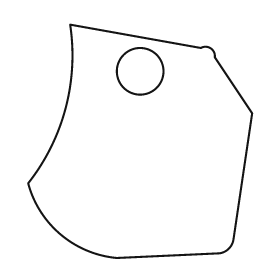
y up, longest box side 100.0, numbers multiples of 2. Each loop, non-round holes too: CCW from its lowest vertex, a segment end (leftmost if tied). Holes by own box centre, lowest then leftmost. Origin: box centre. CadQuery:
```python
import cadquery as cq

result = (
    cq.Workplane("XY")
    .moveTo(-10.0, -50.0)
    .lineTo(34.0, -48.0)
    .threePointArc((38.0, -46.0), (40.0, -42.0))
    .lineTo(48.0, 12.0)
    .lineTo(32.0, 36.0)
    .threePointArc((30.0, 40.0), (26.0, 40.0))
    .lineTo(-30.0, 50.0)
    .threePointArc((-32.0, 14.0), (-48.0, -18.0))
    .threePointArc((-34.0, -40.0), (-10.0, -50.0))
    .close()
    .moveTo(0.0, 30.0)
    .circle(10.0)
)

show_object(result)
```